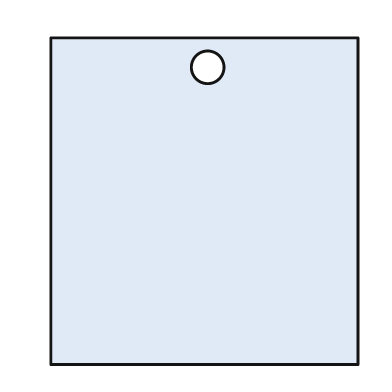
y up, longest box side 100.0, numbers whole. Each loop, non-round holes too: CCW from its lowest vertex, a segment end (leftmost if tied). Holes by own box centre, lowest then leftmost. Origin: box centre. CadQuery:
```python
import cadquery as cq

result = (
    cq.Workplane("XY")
    .moveTo(-47.0, -50.0)
    .lineTo(47.0, -50.0)
    .lineTo(47.0, 50.0)
    .lineTo(-47.0, 50.0)
    .close()
    .moveTo(1.0, 41.0)
    .circle(5.0)
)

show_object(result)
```